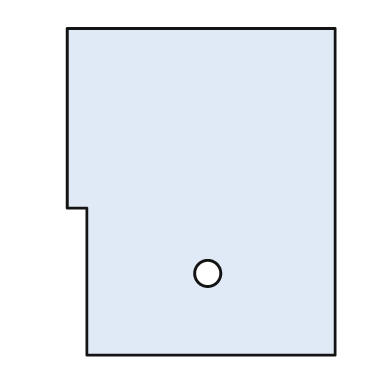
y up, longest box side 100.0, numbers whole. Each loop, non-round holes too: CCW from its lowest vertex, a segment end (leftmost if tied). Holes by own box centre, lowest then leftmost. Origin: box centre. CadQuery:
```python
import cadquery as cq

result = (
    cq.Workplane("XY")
    .moveTo(-35.0, -50.0)
    .lineTo(41.0, -50.0)
    .lineTo(41.0, 50.0)
    .lineTo(-41.0, 50.0)
    .lineTo(-41.0, -5.0)
    .lineTo(-35.0, -5.0)
    .close()
    .moveTo(2.0, -25.0)
    .circle(4.0)
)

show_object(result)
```